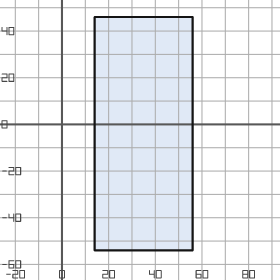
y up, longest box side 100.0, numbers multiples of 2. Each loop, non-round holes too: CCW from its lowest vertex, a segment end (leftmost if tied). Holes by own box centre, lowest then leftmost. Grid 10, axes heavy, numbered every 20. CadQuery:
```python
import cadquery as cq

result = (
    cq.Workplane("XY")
    .moveTo(14.0, -54.0)
    .lineTo(56.0, -54.0)
    .lineTo(56.0, 46.0)
    .lineTo(14.0, 46.0)
    .close()
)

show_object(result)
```